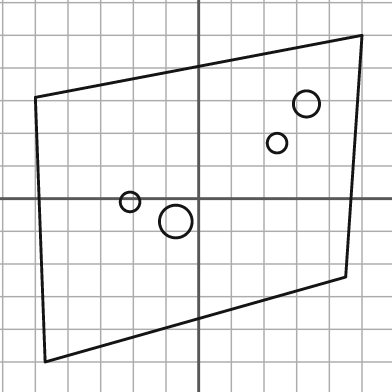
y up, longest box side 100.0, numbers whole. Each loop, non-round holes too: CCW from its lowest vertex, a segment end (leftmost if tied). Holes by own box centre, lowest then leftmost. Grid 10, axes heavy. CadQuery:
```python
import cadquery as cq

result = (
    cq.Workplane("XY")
    .moveTo(-47.0, -50.0)
    .lineTo(45.0, -24.0)
    .lineTo(50.0, 50.0)
    .lineTo(-50.0, 31.0)
    .close()
    .moveTo(-7.0, -7.0)
    .circle(5.0)
    .moveTo(-21.0, -1.0)
    .circle(3.0)
    .moveTo(24.0, 17.0)
    .circle(3.0)
    .moveTo(33.0, 29.0)
    .circle(4.0)
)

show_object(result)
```